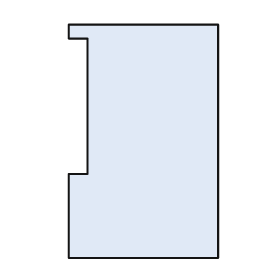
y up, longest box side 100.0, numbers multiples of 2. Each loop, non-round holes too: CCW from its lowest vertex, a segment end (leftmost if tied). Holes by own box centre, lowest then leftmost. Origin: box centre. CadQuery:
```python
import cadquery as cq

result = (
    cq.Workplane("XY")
    .moveTo(-32.0, -50.0)
    .lineTo(32.0, -50.0)
    .lineTo(32.0, 50.0)
    .lineTo(-32.0, 50.0)
    .lineTo(-32.0, 44.0)
    .lineTo(-24.0, 44.0)
    .lineTo(-24.0, -14.0)
    .lineTo(-32.0, -14.0)
    .close()
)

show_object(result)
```